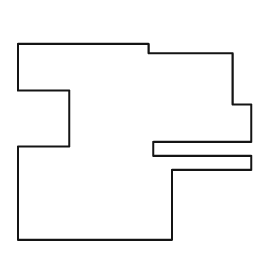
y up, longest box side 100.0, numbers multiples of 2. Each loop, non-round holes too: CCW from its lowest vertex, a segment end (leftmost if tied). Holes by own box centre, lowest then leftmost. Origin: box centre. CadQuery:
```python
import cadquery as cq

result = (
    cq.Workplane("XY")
    .moveTo(-50.0, -42.0)
    .lineTo(16.0, -42.0)
    .lineTo(16.0, -12.0)
    .lineTo(50.0, -12.0)
    .lineTo(50.0, -6.0)
    .lineTo(8.0, -6.0)
    .lineTo(8.0, 0.0)
    .lineTo(50.0, 0.0)
    .lineTo(50.0, 16.0)
    .lineTo(42.0, 16.0)
    .lineTo(42.0, 38.0)
    .lineTo(6.0, 38.0)
    .lineTo(6.0, 42.0)
    .lineTo(-50.0, 42.0)
    .lineTo(-50.0, 22.0)
    .lineTo(-28.0, 22.0)
    .lineTo(-28.0, -2.0)
    .lineTo(-50.0, -2.0)
    .close()
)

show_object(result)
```